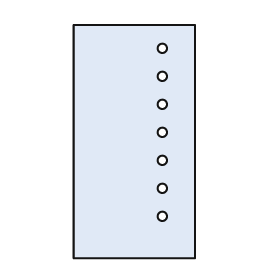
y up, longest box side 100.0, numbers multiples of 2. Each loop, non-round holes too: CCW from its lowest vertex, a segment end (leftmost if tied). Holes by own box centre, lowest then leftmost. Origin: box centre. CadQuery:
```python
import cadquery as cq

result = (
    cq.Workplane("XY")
    .moveTo(-26.0, -50.0)
    .lineTo(26.0, -50.0)
    .lineTo(26.0, 50.0)
    .lineTo(-26.0, 50.0)
    .close()
    .moveTo(12.0, -32.0)
    .circle(2.0)
    .moveTo(12.0, -20.0)
    .circle(2.0)
    .moveTo(12.0, -8.0)
    .circle(2.0)
    .moveTo(12.0, 4.0)
    .circle(2.0)
    .moveTo(12.0, 16.0)
    .circle(2.0)
    .moveTo(12.0, 28.0)
    .circle(2.0)
    .moveTo(12.0, 40.0)
    .circle(2.0)
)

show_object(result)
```